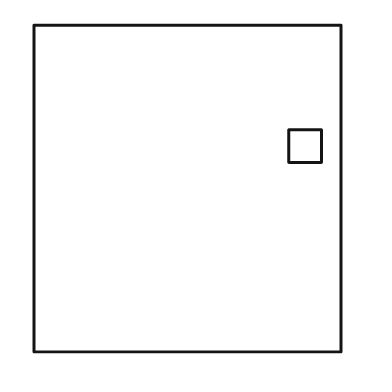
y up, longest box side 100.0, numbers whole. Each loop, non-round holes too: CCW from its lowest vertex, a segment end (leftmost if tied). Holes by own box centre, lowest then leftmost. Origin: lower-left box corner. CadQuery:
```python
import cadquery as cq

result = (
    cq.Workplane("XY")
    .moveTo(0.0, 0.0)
    .lineTo(94.0, 0.0)
    .lineTo(94.0, 100.0)
    .lineTo(0.0, 100.0)
    .close()
    .moveTo(78.0, 58.0)
    .lineTo(88.0, 58.0)
    .lineTo(88.0, 68.0)
    .lineTo(78.0, 68.0)
    .close()
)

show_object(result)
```